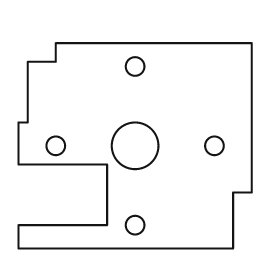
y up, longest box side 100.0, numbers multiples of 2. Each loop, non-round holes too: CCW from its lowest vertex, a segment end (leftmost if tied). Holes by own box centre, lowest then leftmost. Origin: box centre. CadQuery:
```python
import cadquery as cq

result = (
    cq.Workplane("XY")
    .moveTo(-50.0, -44.0)
    .lineTo(42.0, -44.0)
    .lineTo(42.0, -20.0)
    .lineTo(50.0, -20.0)
    .lineTo(50.0, 44.0)
    .lineTo(-34.0, 44.0)
    .lineTo(-34.0, 36.0)
    .lineTo(-46.0, 36.0)
    .lineTo(-46.0, 10.0)
    .lineTo(-50.0, 10.0)
    .lineTo(-50.0, -8.0)
    .lineTo(-12.0, -8.0)
    .lineTo(-12.0, -34.0)
    .lineTo(-50.0, -34.0)
    .close()
    .moveTo(0.0, -34.0)
    .circle(4.0)
    .moveTo(-34.0, 0.0)
    .circle(4.0)
    .moveTo(0.0, 0.0)
    .circle(10.0)
    .moveTo(34.0, 0.0)
    .circle(4.0)
    .moveTo(0.0, 34.0)
    .circle(4.0)
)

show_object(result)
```